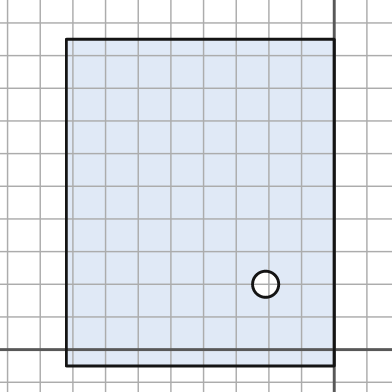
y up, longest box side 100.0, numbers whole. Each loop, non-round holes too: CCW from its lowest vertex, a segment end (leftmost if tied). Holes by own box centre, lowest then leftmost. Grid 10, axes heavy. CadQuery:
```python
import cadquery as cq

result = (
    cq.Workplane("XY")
    .moveTo(-82.0, -5.0)
    .lineTo(0.0, -5.0)
    .lineTo(0.0, 95.0)
    .lineTo(-82.0, 95.0)
    .close()
    .moveTo(-21.0, 20.0)
    .circle(4.0)
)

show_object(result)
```